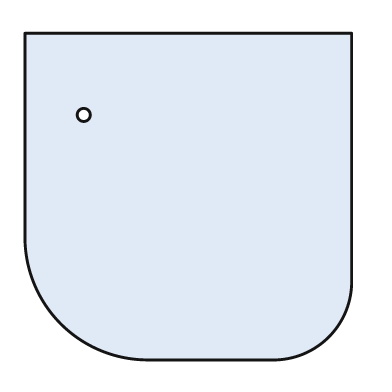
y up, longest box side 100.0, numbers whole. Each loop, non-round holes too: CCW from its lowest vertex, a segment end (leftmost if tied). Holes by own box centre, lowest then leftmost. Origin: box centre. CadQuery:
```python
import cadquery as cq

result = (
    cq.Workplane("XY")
    .moveTo(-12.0, -50.0)
    .lineTo(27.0, -50.0)
    .threePointArc((43.0, -43.0), (50.0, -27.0))
    .lineTo(50.0, 50.0)
    .lineTo(-50.0, 50.0)
    .lineTo(-50.0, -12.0)
    .threePointArc((-39.0, -39.0), (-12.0, -50.0))
    .close()
    .moveTo(-32.0, 25.0)
    .circle(2.0)
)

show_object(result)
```